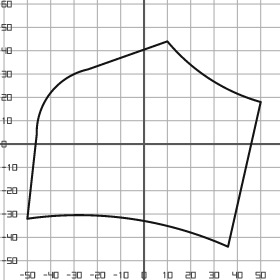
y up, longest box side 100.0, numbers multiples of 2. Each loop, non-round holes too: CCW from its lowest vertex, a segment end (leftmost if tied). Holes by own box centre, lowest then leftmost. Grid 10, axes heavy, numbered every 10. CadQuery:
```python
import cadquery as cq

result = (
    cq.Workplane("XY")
    .moveTo(36.0, -44.0)
    .lineTo(50.0, 18.0)
    .threePointArc((28.0, 28.0), (10.0, 44.0))
    .lineTo(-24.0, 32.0)
    .threePointArc((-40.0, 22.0), (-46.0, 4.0))
    .lineTo(-50.0, -32.0)
    .threePointArc((-6.0, -32.0), (36.0, -44.0))
    .close()
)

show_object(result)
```